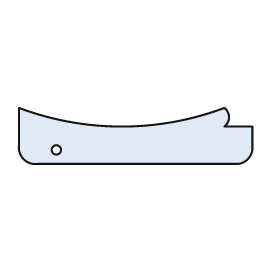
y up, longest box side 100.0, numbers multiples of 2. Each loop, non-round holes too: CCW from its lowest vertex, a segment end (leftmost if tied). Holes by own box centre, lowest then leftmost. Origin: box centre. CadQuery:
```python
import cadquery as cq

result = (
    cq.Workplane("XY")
    .moveTo(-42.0, -12.0)
    .lineTo(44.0, -12.0)
    .threePointArc((48.0, -10.0), (50.0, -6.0))
    .lineTo(50.0, 4.0)
    .lineTo(38.0, 4.0)
    .threePointArc((40.0, 8.0), (38.0, 12.0))
    .threePointArc((-6.0, 4.0), (-50.0, 12.0))
    .lineTo(-50.0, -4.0)
    .threePointArc((-48.0, -10.0), (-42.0, -12.0))
    .close()
    .moveTo(-34.0, -6.0)
    .circle(2.0)
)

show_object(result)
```